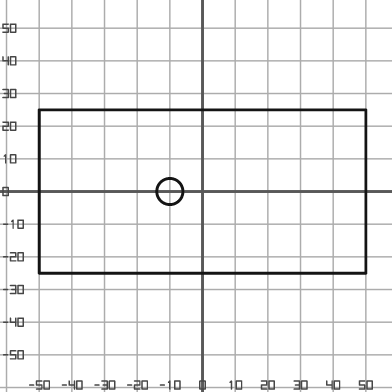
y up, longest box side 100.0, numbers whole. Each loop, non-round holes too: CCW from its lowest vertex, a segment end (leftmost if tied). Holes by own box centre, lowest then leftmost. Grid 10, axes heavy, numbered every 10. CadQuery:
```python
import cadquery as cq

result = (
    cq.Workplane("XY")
    .moveTo(-50.0, -25.0)
    .lineTo(50.0, -25.0)
    .lineTo(50.0, 25.0)
    .lineTo(-50.0, 25.0)
    .close()
    .moveTo(-10.0, 0.0)
    .circle(4.0)
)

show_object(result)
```